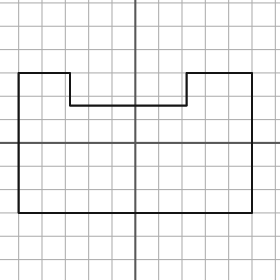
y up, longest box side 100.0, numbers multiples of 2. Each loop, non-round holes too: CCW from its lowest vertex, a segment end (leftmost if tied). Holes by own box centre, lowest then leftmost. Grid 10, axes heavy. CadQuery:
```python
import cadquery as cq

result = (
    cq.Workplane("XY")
    .moveTo(-50.0, -30.0)
    .lineTo(50.0, -30.0)
    .lineTo(50.0, 30.0)
    .lineTo(22.0, 30.0)
    .lineTo(22.0, 16.0)
    .lineTo(-28.0, 16.0)
    .lineTo(-28.0, 30.0)
    .lineTo(-50.0, 30.0)
    .close()
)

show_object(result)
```